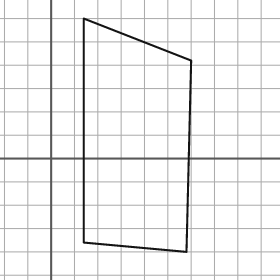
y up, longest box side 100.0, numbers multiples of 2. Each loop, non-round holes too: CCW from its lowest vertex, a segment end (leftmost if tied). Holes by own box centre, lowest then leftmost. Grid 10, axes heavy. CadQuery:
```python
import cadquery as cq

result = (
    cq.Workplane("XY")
    .moveTo(58.0, -40.0)
    .lineTo(60.0, 42.0)
    .lineTo(14.0, 60.0)
    .lineTo(14.0, -36.0)
    .close()
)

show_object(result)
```